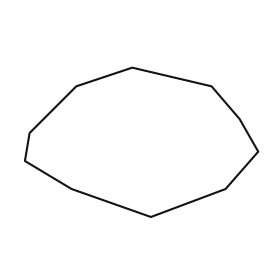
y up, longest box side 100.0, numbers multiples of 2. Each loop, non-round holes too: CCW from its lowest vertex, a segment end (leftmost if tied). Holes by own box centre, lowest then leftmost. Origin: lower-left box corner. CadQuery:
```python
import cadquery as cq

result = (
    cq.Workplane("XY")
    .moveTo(54.0, 0.0)
    .lineTo(86.0, 12.0)
    .lineTo(100.0, 28.0)
    .lineTo(92.0, 42.0)
    .lineTo(80.0, 56.0)
    .lineTo(46.0, 64.0)
    .lineTo(22.0, 56.0)
    .lineTo(2.0, 36.0)
    .lineTo(0.0, 24.0)
    .lineTo(20.0, 12.0)
    .close()
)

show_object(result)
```